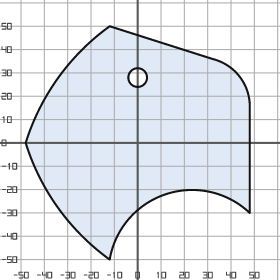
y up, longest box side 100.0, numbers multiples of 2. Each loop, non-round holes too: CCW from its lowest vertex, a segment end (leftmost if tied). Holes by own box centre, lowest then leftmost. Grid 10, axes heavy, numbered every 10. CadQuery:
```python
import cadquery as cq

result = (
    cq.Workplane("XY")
    .moveTo(-12.0, -50.0)
    .threePointArc((12.0, -22.0), (48.0, -30.0))
    .lineTo(48.0, 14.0)
    .threePointArc((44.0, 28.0), (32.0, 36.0))
    .lineTo(-12.0, 50.0)
    .threePointArc((-34.0, 28.0), (-48.0, 0.0))
    .threePointArc((-34.0, -28.0), (-12.0, -50.0))
    .close()
    .moveTo(0.0, 28.0)
    .circle(4.0)
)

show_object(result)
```